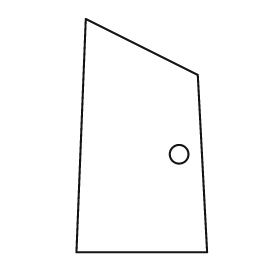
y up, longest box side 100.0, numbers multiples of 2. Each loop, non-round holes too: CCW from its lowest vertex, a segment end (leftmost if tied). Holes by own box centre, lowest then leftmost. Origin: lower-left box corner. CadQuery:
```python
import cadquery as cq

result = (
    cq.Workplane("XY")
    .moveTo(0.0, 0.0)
    .lineTo(56.0, 0.0)
    .lineTo(52.0, 76.0)
    .lineTo(4.0, 100.0)
    .close()
    .moveTo(44.0, 42.0)
    .circle(4.0)
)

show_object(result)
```